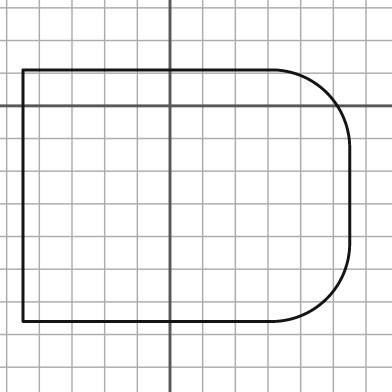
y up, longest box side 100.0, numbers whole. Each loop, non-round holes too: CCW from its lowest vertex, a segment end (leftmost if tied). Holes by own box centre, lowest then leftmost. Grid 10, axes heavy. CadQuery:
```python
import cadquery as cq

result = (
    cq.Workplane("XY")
    .moveTo(-45.0, -66.0)
    .lineTo(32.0, -66.0)
    .threePointArc((48.0, -59.0), (55.0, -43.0))
    .lineTo(55.0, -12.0)
    .threePointArc((48.0, 4.0), (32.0, 11.0))
    .lineTo(-45.0, 11.0)
    .close()
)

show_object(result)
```